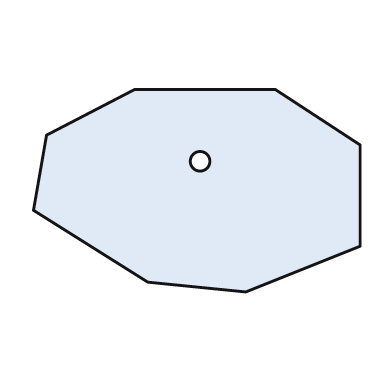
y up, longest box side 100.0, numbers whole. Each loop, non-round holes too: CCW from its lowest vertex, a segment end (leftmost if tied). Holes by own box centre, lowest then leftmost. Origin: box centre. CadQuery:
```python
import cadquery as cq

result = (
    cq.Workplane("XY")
    .moveTo(15.0, -31.0)
    .lineTo(50.0, -17.0)
    .lineTo(50.0, 14.0)
    .lineTo(24.0, 31.0)
    .lineTo(-19.0, 31.0)
    .lineTo(-46.0, 17.0)
    .lineTo(-50.0, -6.0)
    .lineTo(-15.0, -28.0)
    .close()
    .moveTo(1.0, 9.0)
    .circle(3.0)
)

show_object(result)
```